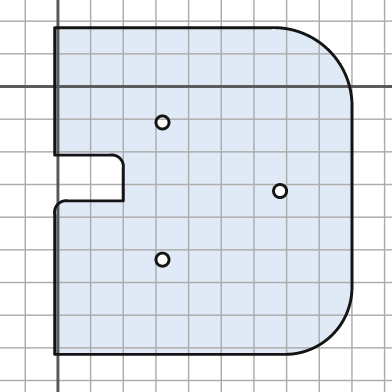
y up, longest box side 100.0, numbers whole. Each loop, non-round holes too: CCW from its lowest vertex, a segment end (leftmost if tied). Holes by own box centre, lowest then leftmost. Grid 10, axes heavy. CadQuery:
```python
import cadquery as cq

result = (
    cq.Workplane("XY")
    .moveTo(-1.0, -82.0)
    .lineTo(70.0, -82.0)
    .threePointArc((84.0, -76.0), (90.0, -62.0))
    .lineTo(90.0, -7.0)
    .threePointArc((83.0, 11.0), (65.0, 18.0))
    .lineTo(-1.0, 18.0)
    .lineTo(-1.0, -21.0)
    .lineTo(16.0, -21.0)
    .threePointArc((19.0, -22.0), (20.0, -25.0))
    .lineTo(20.0, -35.0)
    .lineTo(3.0, -35.0)
    .threePointArc((0.0, -36.0), (-1.0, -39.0))
    .close()
    .moveTo(32.0, -53.0)
    .circle(2.0)
    .moveTo(68.0, -32.0)
    .circle(2.0)
    .moveTo(32.0, -11.0)
    .circle(2.0)
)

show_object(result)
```